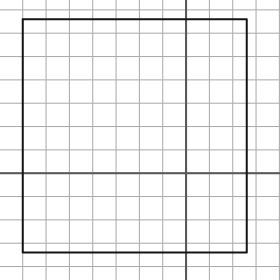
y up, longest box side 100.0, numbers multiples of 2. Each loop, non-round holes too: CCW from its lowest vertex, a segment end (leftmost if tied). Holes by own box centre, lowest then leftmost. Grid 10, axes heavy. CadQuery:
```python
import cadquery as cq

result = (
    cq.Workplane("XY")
    .moveTo(-70.0, -34.0)
    .lineTo(26.0, -34.0)
    .lineTo(26.0, 66.0)
    .lineTo(-70.0, 66.0)
    .close()
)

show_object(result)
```